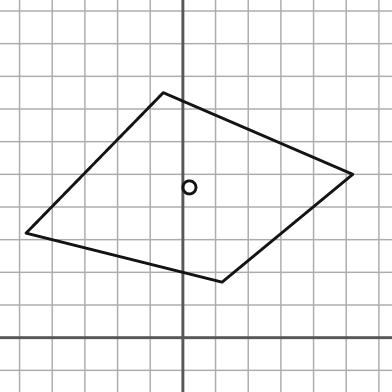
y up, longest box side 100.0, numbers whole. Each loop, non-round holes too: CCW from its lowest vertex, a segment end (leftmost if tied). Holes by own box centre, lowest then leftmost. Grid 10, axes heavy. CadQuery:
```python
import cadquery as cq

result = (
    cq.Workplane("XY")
    .moveTo(12.0, 17.0)
    .lineTo(52.0, 50.0)
    .lineTo(-6.0, 75.0)
    .lineTo(-48.0, 32.0)
    .close()
    .moveTo(2.0, 46.0)
    .circle(2.0)
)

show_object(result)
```